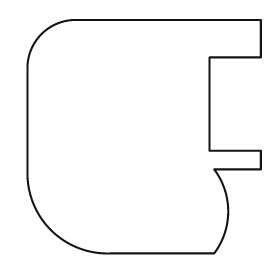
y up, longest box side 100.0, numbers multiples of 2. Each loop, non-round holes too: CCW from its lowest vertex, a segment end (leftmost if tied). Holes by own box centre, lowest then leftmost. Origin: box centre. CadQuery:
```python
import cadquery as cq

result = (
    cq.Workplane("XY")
    .moveTo(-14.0, -50.0)
    .lineTo(30.0, -50.0)
    .threePointArc((36.0, -32.0), (30.0, -14.0))
    .lineTo(50.0, -14.0)
    .lineTo(50.0, -6.0)
    .lineTo(28.0, -6.0)
    .lineTo(28.0, 34.0)
    .lineTo(50.0, 34.0)
    .lineTo(50.0, 50.0)
    .lineTo(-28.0, 50.0)
    .threePointArc((-44.0, 44.0), (-50.0, 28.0))
    .lineTo(-50.0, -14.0)
    .threePointArc((-40.0, -40.0), (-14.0, -50.0))
    .close()
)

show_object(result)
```